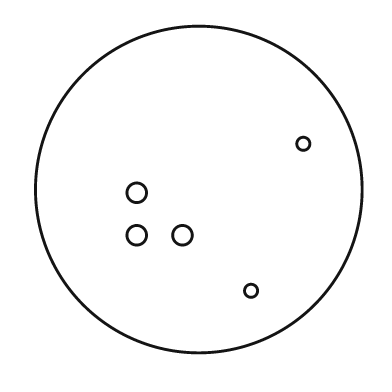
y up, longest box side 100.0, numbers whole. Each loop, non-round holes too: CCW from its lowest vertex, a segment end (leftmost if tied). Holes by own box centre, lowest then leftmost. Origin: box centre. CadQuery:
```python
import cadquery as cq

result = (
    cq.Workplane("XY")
    .moveTo(0.0, 0.0)
    .circle(50.0)
    .moveTo(16.0, -31.0)
    .circle(2.0)
    .moveTo(-19.0, -14.0)
    .circle(3.0)
    .moveTo(-5.0, -14.0)
    .circle(3.0)
    .moveTo(-19.0, -1.0)
    .circle(3.0)
    .moveTo(32.0, 14.0)
    .circle(2.0)
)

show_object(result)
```